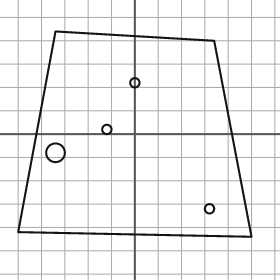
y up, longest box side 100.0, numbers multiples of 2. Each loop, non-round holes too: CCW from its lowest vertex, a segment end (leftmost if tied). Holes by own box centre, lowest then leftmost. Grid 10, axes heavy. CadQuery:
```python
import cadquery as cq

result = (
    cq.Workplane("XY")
    .moveTo(50.0, -44.0)
    .lineTo(34.0, 40.0)
    .lineTo(-34.0, 44.0)
    .lineTo(-50.0, -42.0)
    .close()
    .moveTo(32.0, -32.0)
    .circle(2.0)
    .moveTo(-34.0, -8.0)
    .circle(4.0)
    .moveTo(-12.0, 2.0)
    .circle(2.0)
    .moveTo(0.0, 22.0)
    .circle(2.0)
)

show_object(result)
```